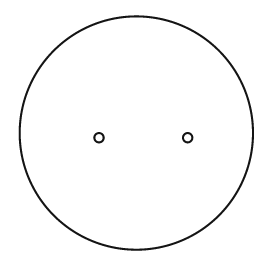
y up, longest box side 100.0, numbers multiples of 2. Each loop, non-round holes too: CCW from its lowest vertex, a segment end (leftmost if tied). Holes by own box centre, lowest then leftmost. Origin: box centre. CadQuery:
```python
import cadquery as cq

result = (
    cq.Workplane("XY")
    .moveTo(0.0, 0.0)
    .circle(50.0)
    .moveTo(-16.0, -2.0)
    .circle(2.0)
    .moveTo(22.0, -2.0)
    .circle(2.0)
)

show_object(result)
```